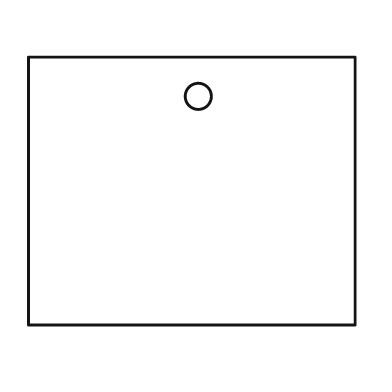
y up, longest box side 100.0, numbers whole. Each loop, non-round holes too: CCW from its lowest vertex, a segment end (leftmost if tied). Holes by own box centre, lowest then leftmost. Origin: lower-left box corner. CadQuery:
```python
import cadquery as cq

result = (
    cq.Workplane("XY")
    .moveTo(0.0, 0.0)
    .lineTo(100.0, 0.0)
    .lineTo(100.0, 82.0)
    .lineTo(0.0, 82.0)
    .close()
    .moveTo(52.0, 70.0)
    .circle(4.0)
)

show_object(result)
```